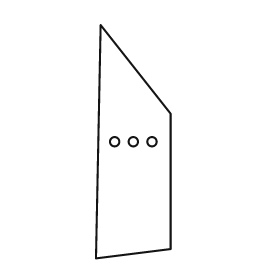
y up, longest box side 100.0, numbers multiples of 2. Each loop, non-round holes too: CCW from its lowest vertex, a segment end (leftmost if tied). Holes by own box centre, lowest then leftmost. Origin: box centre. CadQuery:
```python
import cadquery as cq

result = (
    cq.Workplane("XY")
    .moveTo(-16.0, -50.0)
    .lineTo(16.0, -46.0)
    .lineTo(16.0, 12.0)
    .lineTo(-14.0, 50.0)
    .close()
    .moveTo(-8.0, 0.0)
    .circle(2.0)
    .moveTo(0.0, 0.0)
    .circle(2.0)
    .moveTo(8.0, 0.0)
    .circle(2.0)
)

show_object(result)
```